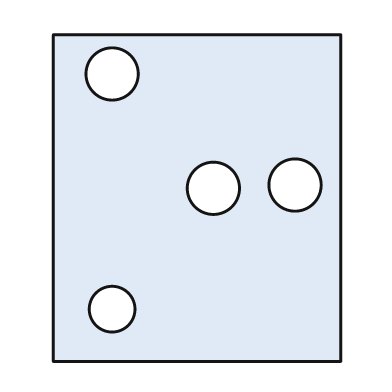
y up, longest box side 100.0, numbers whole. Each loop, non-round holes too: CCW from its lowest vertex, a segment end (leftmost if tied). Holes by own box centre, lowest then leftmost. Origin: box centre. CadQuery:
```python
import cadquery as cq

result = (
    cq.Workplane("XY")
    .moveTo(-44.0, -50.0)
    .lineTo(44.0, -50.0)
    .lineTo(44.0, 50.0)
    .lineTo(-44.0, 50.0)
    .close()
    .moveTo(-26.0, -34.0)
    .circle(7.0)
    .moveTo(5.0, 3.0)
    .circle(8.0)
    .moveTo(30.0, 4.0)
    .circle(8.0)
    .moveTo(-26.0, 38.0)
    .circle(8.0)
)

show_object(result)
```